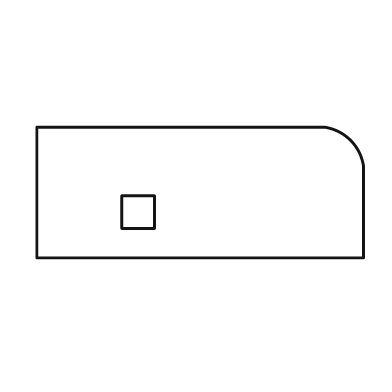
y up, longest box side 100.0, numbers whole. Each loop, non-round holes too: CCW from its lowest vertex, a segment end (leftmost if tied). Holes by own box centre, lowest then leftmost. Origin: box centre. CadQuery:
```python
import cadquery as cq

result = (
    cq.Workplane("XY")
    .moveTo(-50.0, -20.0)
    .lineTo(50.0, -20.0)
    .lineTo(50.0, 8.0)
    .threePointArc((46.0, 16.0), (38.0, 20.0))
    .lineTo(-50.0, 20.0)
    .close()
    .moveTo(-24.0, -11.0)
    .lineTo(-14.0, -11.0)
    .lineTo(-14.0, -1.0)
    .lineTo(-24.0, -1.0)
    .close()
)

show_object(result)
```